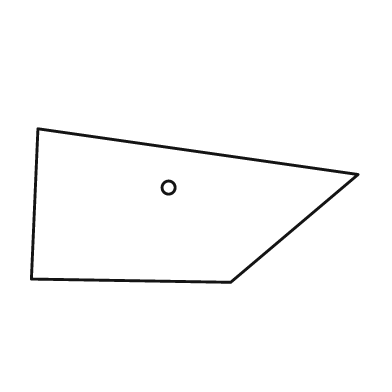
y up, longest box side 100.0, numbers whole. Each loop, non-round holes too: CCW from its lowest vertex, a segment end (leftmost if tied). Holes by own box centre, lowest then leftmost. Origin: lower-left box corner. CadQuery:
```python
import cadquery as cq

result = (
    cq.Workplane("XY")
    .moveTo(61.0, 0.0)
    .lineTo(100.0, 33.0)
    .lineTo(2.0, 47.0)
    .lineTo(0.0, 1.0)
    .close()
    .moveTo(42.0, 29.0)
    .circle(2.0)
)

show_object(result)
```